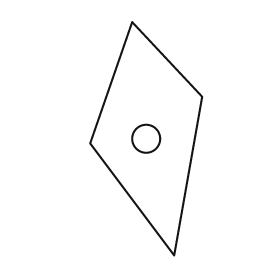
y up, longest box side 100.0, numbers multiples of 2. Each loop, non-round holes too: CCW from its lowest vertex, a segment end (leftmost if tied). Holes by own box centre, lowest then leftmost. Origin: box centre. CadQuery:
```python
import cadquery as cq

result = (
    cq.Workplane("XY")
    .moveTo(12.0, -50.0)
    .lineTo(24.0, 18.0)
    .lineTo(-6.0, 50.0)
    .lineTo(-24.0, -2.0)
    .close()
    .moveTo(0.0, 0.0)
    .circle(6.0)
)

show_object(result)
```